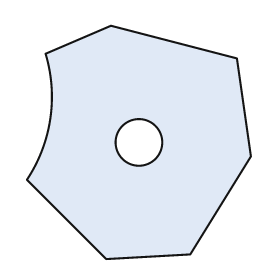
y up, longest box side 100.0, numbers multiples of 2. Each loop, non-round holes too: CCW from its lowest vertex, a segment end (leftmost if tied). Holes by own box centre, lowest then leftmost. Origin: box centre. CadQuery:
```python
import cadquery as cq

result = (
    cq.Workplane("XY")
    .moveTo(-14.0, -50.0)
    .lineTo(22.0, -48.0)
    .lineTo(48.0, -6.0)
    .lineTo(42.0, 36.0)
    .lineTo(-12.0, 50.0)
    .lineTo(-40.0, 38.0)
    .threePointArc((-38.0, 10.0), (-48.0, -16.0))
    .close()
    .moveTo(0.0, 0.0)
    .circle(10.0)
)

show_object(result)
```